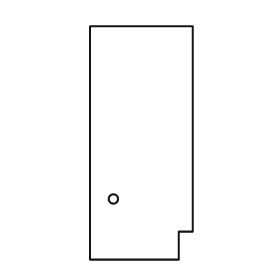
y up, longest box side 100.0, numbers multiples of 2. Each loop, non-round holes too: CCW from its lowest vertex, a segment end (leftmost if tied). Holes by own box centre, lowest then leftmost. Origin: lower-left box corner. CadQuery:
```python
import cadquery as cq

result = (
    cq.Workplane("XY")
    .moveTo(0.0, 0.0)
    .lineTo(38.0, 0.0)
    .lineTo(38.0, 12.0)
    .lineTo(44.0, 12.0)
    .lineTo(44.0, 100.0)
    .lineTo(0.0, 100.0)
    .close()
    .moveTo(10.0, 26.0)
    .circle(2.0)
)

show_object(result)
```